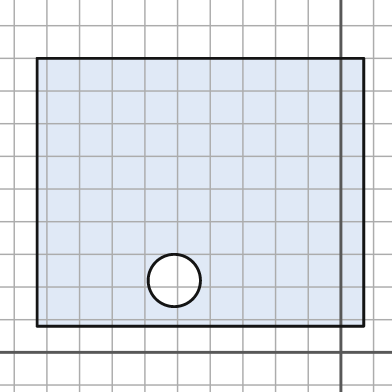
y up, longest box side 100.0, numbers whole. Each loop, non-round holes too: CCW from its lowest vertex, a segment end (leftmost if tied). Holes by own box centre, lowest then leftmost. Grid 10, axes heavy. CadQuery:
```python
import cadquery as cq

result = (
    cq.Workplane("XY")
    .moveTo(-93.0, 8.0)
    .lineTo(7.0, 8.0)
    .lineTo(7.0, 90.0)
    .lineTo(-93.0, 90.0)
    .close()
    .moveTo(-51.0, 22.0)
    .circle(8.0)
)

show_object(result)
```